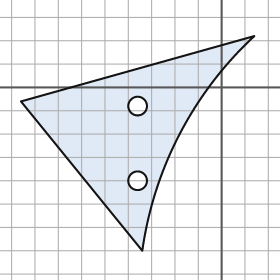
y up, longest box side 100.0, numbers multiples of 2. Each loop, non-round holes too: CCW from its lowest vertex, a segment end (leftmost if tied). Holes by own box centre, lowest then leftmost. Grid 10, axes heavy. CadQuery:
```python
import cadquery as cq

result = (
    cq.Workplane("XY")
    .moveTo(-34.0, -70.0)
    .threePointArc((-18.0, -20.0), (14.0, 22.0))
    .lineTo(-86.0, -6.0)
    .close()
    .moveTo(-36.0, -40.0)
    .circle(4.0)
    .moveTo(-36.0, -8.0)
    .circle(4.0)
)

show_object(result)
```